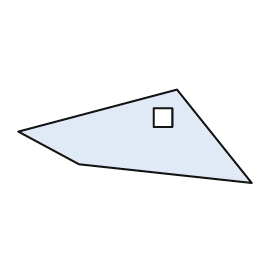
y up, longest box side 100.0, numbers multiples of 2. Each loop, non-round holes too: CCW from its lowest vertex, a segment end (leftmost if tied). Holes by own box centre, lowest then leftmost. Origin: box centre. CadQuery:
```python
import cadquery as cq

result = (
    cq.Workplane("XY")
    .moveTo(50.0, -20.0)
    .lineTo(18.0, 20.0)
    .lineTo(-50.0, 2.0)
    .lineTo(-24.0, -12.0)
    .close()
    .moveTo(8.0, 4.0)
    .lineTo(16.0, 4.0)
    .lineTo(16.0, 12.0)
    .lineTo(8.0, 12.0)
    .close()
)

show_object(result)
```